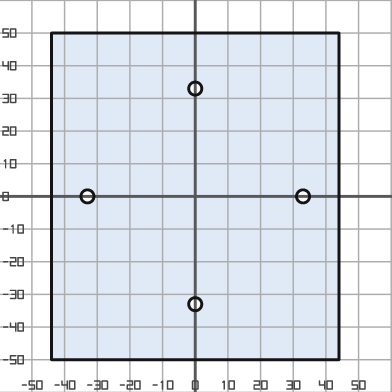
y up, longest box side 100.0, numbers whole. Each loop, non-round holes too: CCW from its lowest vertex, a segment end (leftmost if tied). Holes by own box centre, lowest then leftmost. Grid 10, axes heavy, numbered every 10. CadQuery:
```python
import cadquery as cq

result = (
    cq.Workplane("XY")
    .moveTo(-44.0, -50.0)
    .lineTo(44.0, -50.0)
    .lineTo(44.0, 50.0)
    .lineTo(-44.0, 50.0)
    .close()
    .moveTo(0.0, -33.0)
    .circle(2.0)
    .moveTo(-33.0, 0.0)
    .circle(2.0)
    .moveTo(33.0, 0.0)
    .circle(2.0)
    .moveTo(0.0, 33.0)
    .circle(2.0)
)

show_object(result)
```